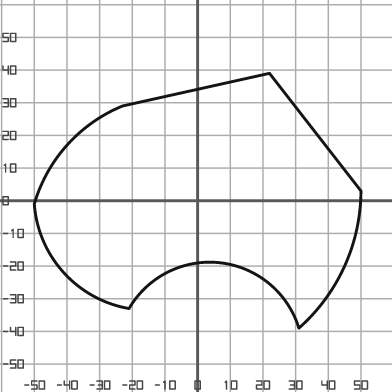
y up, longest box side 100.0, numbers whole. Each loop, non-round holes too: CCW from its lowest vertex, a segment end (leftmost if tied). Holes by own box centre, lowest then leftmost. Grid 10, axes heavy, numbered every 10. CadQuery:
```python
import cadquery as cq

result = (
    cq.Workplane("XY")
    .moveTo(31.0, -39.0)
    .threePointArc((45.0, -20.0), (50.0, 3.0))
    .lineTo(22.0, 39.0)
    .lineTo(-23.0, 29.0)
    .threePointArc((-40.0, 17.0), (-50.0, -1.0))
    .threePointArc((-41.0, -22.0), (-21.0, -33.0))
    .threePointArc((7.0, -19.0), (31.0, -39.0))
    .close()
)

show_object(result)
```